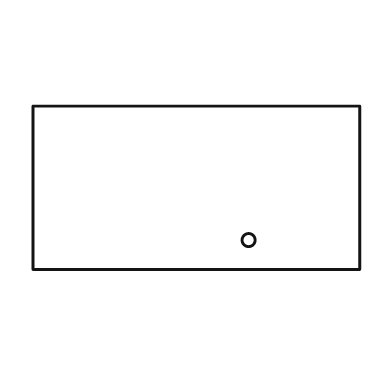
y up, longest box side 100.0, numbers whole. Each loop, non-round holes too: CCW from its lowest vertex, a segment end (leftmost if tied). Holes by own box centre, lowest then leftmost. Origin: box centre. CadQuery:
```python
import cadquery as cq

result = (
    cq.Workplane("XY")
    .moveTo(-50.0, -25.0)
    .lineTo(50.0, -25.0)
    .lineTo(50.0, 25.0)
    .lineTo(-50.0, 25.0)
    .close()
    .moveTo(16.0, -16.0)
    .circle(2.0)
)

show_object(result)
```